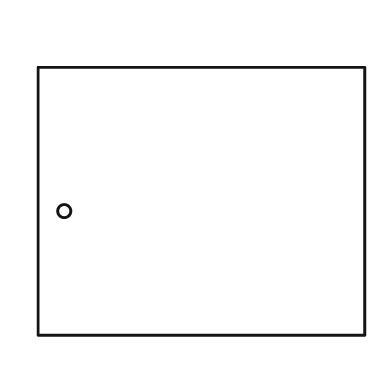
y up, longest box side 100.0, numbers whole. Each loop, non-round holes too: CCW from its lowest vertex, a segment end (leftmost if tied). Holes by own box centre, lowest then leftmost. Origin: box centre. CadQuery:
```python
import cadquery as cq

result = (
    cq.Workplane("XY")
    .moveTo(-50.0, -41.0)
    .lineTo(50.0, -41.0)
    .lineTo(50.0, 41.0)
    .lineTo(-50.0, 41.0)
    .close()
    .moveTo(-42.0, -3.0)
    .circle(2.0)
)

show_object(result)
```